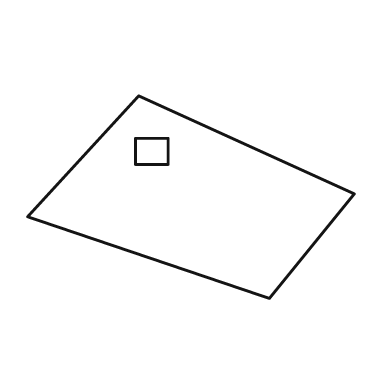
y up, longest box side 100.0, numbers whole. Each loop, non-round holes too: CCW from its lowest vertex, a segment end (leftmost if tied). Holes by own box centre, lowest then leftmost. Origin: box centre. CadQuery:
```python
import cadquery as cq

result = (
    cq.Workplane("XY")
    .moveTo(24.0, -31.0)
    .lineTo(50.0, 1.0)
    .lineTo(-16.0, 31.0)
    .lineTo(-50.0, -6.0)
    .close()
    .moveTo(-17.0, 10.0)
    .lineTo(-7.0, 10.0)
    .lineTo(-7.0, 18.0)
    .lineTo(-17.0, 18.0)
    .close()
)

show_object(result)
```